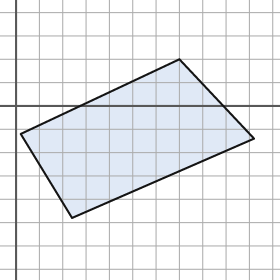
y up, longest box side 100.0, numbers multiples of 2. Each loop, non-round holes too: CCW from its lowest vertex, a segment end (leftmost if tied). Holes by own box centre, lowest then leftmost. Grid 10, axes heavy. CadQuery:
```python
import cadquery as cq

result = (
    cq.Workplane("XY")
    .moveTo(24.0, -48.0)
    .lineTo(102.0, -14.0)
    .lineTo(70.0, 20.0)
    .lineTo(2.0, -12.0)
    .close()
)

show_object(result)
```